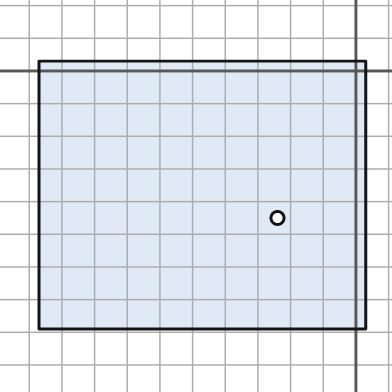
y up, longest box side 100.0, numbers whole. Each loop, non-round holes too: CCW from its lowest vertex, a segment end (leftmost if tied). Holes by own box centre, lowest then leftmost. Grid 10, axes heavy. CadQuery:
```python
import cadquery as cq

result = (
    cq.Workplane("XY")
    .moveTo(-97.0, -79.0)
    .lineTo(3.0, -79.0)
    .lineTo(3.0, 3.0)
    .lineTo(-97.0, 3.0)
    .close()
    .moveTo(-24.0, -45.0)
    .circle(2.0)
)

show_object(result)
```